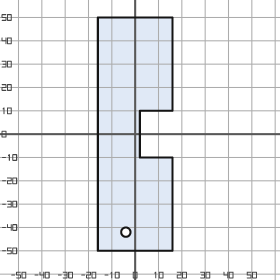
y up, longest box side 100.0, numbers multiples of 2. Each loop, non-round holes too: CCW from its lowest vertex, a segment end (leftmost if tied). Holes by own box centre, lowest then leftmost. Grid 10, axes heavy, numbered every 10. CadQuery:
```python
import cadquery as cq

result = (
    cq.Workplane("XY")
    .moveTo(-16.0, -50.0)
    .lineTo(16.0, -50.0)
    .lineTo(16.0, -10.0)
    .lineTo(2.0, -10.0)
    .lineTo(2.0, 10.0)
    .lineTo(16.0, 10.0)
    .lineTo(16.0, 50.0)
    .lineTo(-16.0, 50.0)
    .close()
    .moveTo(-4.0, -42.0)
    .circle(2.0)
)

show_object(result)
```